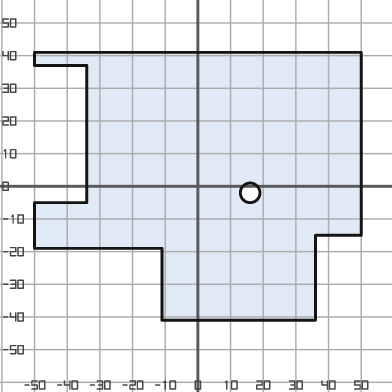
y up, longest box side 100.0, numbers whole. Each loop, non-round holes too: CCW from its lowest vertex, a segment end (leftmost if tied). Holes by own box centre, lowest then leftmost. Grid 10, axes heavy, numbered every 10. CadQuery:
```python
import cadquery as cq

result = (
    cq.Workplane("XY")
    .moveTo(-11.0, -41.0)
    .lineTo(36.0, -41.0)
    .lineTo(36.0, -15.0)
    .lineTo(50.0, -15.0)
    .lineTo(50.0, 41.0)
    .lineTo(-50.0, 41.0)
    .lineTo(-50.0, 37.0)
    .lineTo(-34.0, 37.0)
    .lineTo(-34.0, -5.0)
    .lineTo(-50.0, -5.0)
    .lineTo(-50.0, -19.0)
    .lineTo(-11.0, -19.0)
    .close()
    .moveTo(16.0, -2.0)
    .circle(3.0)
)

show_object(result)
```